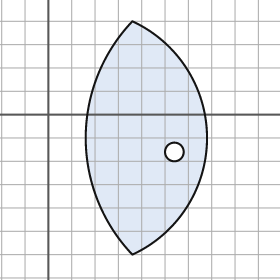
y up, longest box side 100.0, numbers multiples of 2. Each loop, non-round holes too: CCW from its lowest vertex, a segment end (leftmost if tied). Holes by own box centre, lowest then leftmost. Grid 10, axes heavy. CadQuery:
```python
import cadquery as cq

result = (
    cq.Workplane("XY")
    .moveTo(36.0, -60.0)
    .threePointArc((68.0, -10.0), (36.0, 40.0))
    .threePointArc((16.0, -10.0), (36.0, -60.0))
    .close()
    .moveTo(54.0, -16.0)
    .circle(4.0)
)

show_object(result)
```